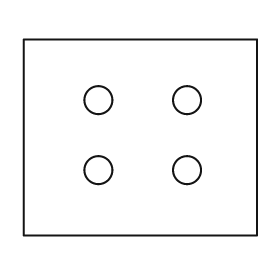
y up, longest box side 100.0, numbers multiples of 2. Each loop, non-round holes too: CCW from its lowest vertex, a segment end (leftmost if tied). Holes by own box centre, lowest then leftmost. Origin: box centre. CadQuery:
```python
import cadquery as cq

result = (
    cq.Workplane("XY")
    .moveTo(-50.0, -42.0)
    .lineTo(50.0, -42.0)
    .lineTo(50.0, 42.0)
    .lineTo(-50.0, 42.0)
    .close()
    .moveTo(-18.0, -14.0)
    .circle(6.0)
    .moveTo(20.0, -14.0)
    .circle(6.0)
    .moveTo(-18.0, 16.0)
    .circle(6.0)
    .moveTo(20.0, 16.0)
    .circle(6.0)
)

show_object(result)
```